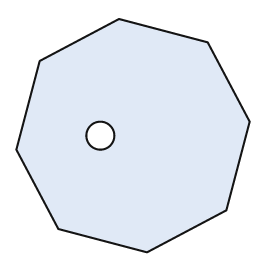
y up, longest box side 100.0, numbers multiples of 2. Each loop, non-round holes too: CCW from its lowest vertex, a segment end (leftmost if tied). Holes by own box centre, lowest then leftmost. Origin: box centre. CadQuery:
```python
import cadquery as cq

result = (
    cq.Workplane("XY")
    .moveTo(6.0, -50.0)
    .lineTo(40.0, -32.0)
    .lineTo(50.0, 6.0)
    .lineTo(32.0, 40.0)
    .lineTo(-6.0, 50.0)
    .lineTo(-40.0, 32.0)
    .lineTo(-50.0, -6.0)
    .lineTo(-32.0, -40.0)
    .close()
    .moveTo(-14.0, 0.0)
    .circle(6.0)
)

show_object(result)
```